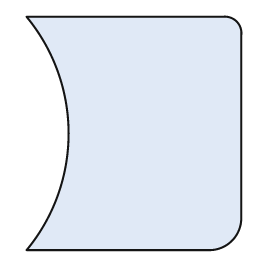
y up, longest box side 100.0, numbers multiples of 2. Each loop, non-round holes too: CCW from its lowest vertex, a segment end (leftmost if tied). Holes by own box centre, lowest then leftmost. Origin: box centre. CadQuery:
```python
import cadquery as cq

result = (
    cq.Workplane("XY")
    .moveTo(-46.0, -50.0)
    .lineTo(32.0, -50.0)
    .threePointArc((42.0, -46.0), (46.0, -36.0))
    .lineTo(46.0, 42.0)
    .threePointArc((44.0, 48.0), (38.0, 50.0))
    .lineTo(-46.0, 50.0)
    .threePointArc((-28.0, 0.0), (-46.0, -50.0))
    .close()
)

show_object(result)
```